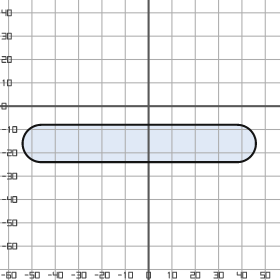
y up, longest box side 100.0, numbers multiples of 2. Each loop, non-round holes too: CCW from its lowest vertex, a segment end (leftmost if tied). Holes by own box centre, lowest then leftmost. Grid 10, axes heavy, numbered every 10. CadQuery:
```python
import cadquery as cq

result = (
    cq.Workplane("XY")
    .moveTo(-46.0, -24.0)
    .lineTo(38.0, -24.0)
    .threePointArc((46.0, -16.0), (38.0, -8.0))
    .lineTo(-46.0, -8.0)
    .threePointArc((-54.0, -16.0), (-46.0, -24.0))
    .close()
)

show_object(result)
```